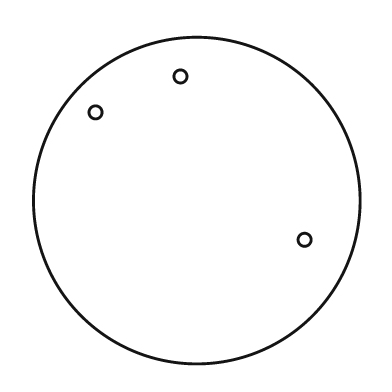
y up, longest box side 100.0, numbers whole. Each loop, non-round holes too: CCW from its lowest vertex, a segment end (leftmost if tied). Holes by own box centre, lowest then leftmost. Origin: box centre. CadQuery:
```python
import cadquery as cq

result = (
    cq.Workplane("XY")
    .moveTo(0.0, 0.0)
    .circle(50.0)
    .moveTo(33.0, -12.0)
    .circle(2.0)
    .moveTo(-31.0, 27.0)
    .circle(2.0)
    .moveTo(-5.0, 38.0)
    .circle(2.0)
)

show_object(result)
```